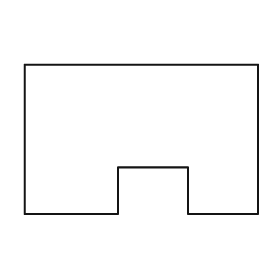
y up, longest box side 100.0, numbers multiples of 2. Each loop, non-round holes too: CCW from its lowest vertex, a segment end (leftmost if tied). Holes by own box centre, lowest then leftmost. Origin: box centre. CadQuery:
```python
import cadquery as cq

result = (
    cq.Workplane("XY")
    .moveTo(-50.0, -32.0)
    .lineTo(-10.0, -32.0)
    .lineTo(-10.0, -12.0)
    .lineTo(20.0, -12.0)
    .lineTo(20.0, -32.0)
    .lineTo(50.0, -32.0)
    .lineTo(50.0, 32.0)
    .lineTo(-50.0, 32.0)
    .close()
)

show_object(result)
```